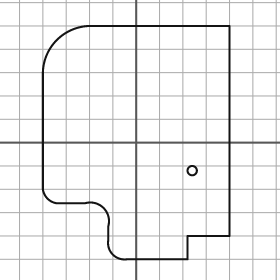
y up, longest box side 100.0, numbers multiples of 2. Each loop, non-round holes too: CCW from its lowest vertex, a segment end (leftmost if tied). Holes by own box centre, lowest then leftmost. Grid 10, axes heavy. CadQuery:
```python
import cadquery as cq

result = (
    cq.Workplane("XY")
    .moveTo(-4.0, -50.0)
    .lineTo(22.0, -50.0)
    .lineTo(22.0, -40.0)
    .lineTo(40.0, -40.0)
    .lineTo(40.0, 50.0)
    .lineTo(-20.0, 50.0)
    .threePointArc((-34.0, 44.0), (-40.0, 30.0))
    .lineTo(-40.0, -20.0)
    .threePointArc((-38.0, -24.0), (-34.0, -26.0))
    .lineTo(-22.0, -26.0)
    .threePointArc((-14.0, -28.0), (-12.0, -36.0))
    .lineTo(-12.0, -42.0)
    .threePointArc((-10.0, -48.0), (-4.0, -50.0))
    .close()
    .moveTo(24.0, -12.0)
    .circle(2.0)
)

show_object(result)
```